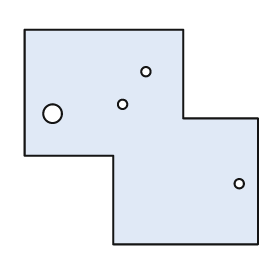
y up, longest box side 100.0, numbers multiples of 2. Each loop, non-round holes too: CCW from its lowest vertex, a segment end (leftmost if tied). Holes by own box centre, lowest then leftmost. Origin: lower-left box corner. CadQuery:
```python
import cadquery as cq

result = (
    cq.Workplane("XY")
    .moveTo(38.0, 0.0)
    .lineTo(100.0, 0.0)
    .lineTo(100.0, 54.0)
    .lineTo(68.0, 54.0)
    .lineTo(68.0, 92.0)
    .lineTo(0.0, 92.0)
    .lineTo(0.0, 38.0)
    .lineTo(38.0, 38.0)
    .close()
    .moveTo(92.0, 26.0)
    .circle(2.0)
    .moveTo(12.0, 56.0)
    .circle(4.0)
    .moveTo(42.0, 60.0)
    .circle(2.0)
    .moveTo(52.0, 74.0)
    .circle(2.0)
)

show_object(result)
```